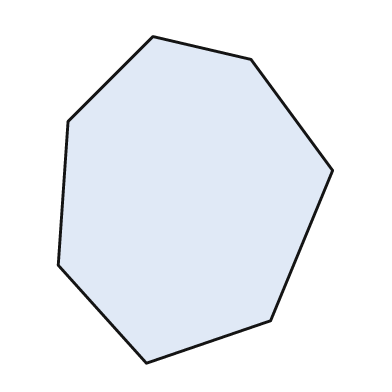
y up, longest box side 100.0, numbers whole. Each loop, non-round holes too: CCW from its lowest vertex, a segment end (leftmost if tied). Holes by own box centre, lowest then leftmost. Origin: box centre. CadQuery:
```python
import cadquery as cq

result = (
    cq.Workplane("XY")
    .moveTo(-15.0, -50.0)
    .lineTo(23.0, -37.0)
    .lineTo(42.0, 9.0)
    .lineTo(17.0, 43.0)
    .lineTo(-13.0, 50.0)
    .lineTo(-39.0, 24.0)
    .lineTo(-42.0, -20.0)
    .close()
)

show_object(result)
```